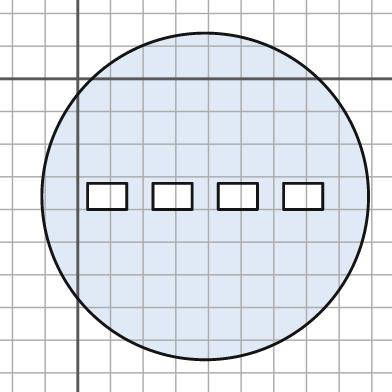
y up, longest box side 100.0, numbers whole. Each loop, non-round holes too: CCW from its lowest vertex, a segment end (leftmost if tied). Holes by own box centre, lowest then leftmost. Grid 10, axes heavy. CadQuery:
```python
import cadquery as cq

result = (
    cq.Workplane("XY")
    .moveTo(39.0, -36.0)
    .circle(50.0)
    .moveTo(3.0, -40.0)
    .lineTo(15.0, -40.0)
    .lineTo(15.0, -32.0)
    .lineTo(3.0, -32.0)
    .close()
    .moveTo(23.0, -40.0)
    .lineTo(35.0, -40.0)
    .lineTo(35.0, -32.0)
    .lineTo(23.0, -32.0)
    .close()
    .moveTo(43.0, -40.0)
    .lineTo(55.0, -40.0)
    .lineTo(55.0, -32.0)
    .lineTo(43.0, -32.0)
    .close()
    .moveTo(63.0, -40.0)
    .lineTo(75.0, -40.0)
    .lineTo(75.0, -32.0)
    .lineTo(63.0, -32.0)
    .close()
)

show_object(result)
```